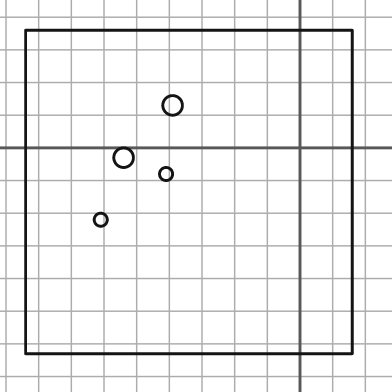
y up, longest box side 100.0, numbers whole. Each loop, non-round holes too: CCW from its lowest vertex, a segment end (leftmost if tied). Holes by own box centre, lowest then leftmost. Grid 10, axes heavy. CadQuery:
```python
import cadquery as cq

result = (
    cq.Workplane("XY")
    .moveTo(-84.0, -63.0)
    .lineTo(16.0, -63.0)
    .lineTo(16.0, 36.0)
    .lineTo(-84.0, 36.0)
    .close()
    .moveTo(-61.0, -22.0)
    .circle(2.0)
    .moveTo(-41.0, -8.0)
    .circle(2.0)
    .moveTo(-54.0, -3.0)
    .circle(3.0)
    .moveTo(-39.0, 13.0)
    .circle(3.0)
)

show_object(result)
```